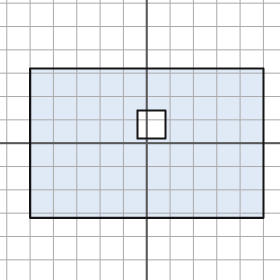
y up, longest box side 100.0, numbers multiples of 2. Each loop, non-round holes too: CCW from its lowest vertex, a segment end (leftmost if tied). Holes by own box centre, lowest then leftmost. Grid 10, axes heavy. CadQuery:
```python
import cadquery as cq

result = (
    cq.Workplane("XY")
    .moveTo(-50.0, -32.0)
    .lineTo(50.0, -32.0)
    .lineTo(50.0, 32.0)
    .lineTo(-50.0, 32.0)
    .close()
    .moveTo(-4.0, 2.0)
    .lineTo(8.0, 2.0)
    .lineTo(8.0, 14.0)
    .lineTo(-4.0, 14.0)
    .close()
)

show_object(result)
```